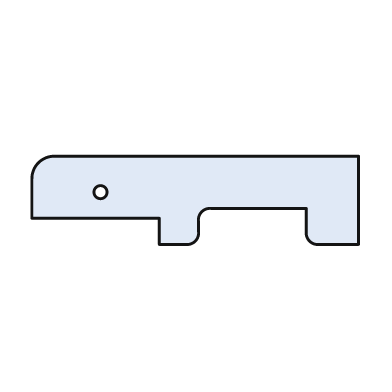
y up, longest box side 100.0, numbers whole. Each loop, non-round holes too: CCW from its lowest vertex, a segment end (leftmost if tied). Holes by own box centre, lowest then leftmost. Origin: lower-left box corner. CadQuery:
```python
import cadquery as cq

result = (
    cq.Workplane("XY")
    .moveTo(39.0, 0.0)
    .lineTo(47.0, 0.0)
    .threePointArc((50.0, 1.0), (51.0, 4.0))
    .lineTo(51.0, 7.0)
    .threePointArc((52.0, 10.0), (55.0, 11.0))
    .lineTo(84.0, 11.0)
    .lineTo(84.0, 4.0)
    .threePointArc((85.0, 1.0), (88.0, 0.0))
    .lineTo(100.0, 0.0)
    .lineTo(100.0, 27.0)
    .lineTo(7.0, 27.0)
    .threePointArc((2.0, 25.0), (0.0, 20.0))
    .lineTo(0.0, 8.0)
    .lineTo(39.0, 8.0)
    .close()
    .moveTo(21.0, 16.0)
    .circle(2.0)
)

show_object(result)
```